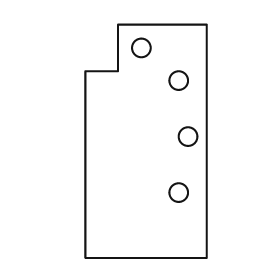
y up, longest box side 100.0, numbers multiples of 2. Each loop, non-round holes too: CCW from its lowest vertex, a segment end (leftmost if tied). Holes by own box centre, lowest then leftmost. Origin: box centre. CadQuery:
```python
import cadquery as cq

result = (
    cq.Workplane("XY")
    .moveTo(-26.0, -50.0)
    .lineTo(26.0, -50.0)
    .lineTo(26.0, 50.0)
    .lineTo(-12.0, 50.0)
    .lineTo(-12.0, 30.0)
    .lineTo(-26.0, 30.0)
    .close()
    .moveTo(14.0, -22.0)
    .circle(4.0)
    .moveTo(18.0, 2.0)
    .circle(4.0)
    .moveTo(14.0, 26.0)
    .circle(4.0)
    .moveTo(-2.0, 40.0)
    .circle(4.0)
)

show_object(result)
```